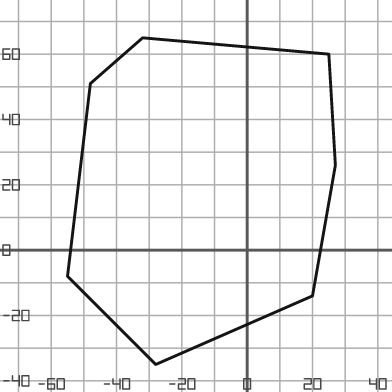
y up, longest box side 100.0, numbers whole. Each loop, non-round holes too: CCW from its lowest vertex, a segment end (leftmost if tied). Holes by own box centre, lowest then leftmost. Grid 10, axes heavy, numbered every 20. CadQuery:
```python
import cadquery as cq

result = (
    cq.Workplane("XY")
    .moveTo(-28.0, -35.0)
    .lineTo(20.0, -14.0)
    .lineTo(27.0, 26.0)
    .lineTo(25.0, 60.0)
    .lineTo(-32.0, 65.0)
    .lineTo(-48.0, 51.0)
    .lineTo(-55.0, -8.0)
    .close()
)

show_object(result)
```